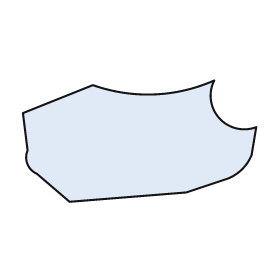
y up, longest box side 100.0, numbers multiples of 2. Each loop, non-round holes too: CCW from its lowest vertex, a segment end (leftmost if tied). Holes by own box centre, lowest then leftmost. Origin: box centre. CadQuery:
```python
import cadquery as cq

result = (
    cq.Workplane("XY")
    .moveTo(-30.0, -26.0)
    .lineTo(20.0, -22.0)
    .lineTo(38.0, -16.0)
    .threePointArc((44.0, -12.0), (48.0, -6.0))
    .lineTo(50.0, 6.0)
    .threePointArc((34.0, 10.0), (32.0, 26.0))
    .threePointArc((6.0, 20.0), (-20.0, 24.0))
    .lineTo(-50.0, 12.0)
    .lineTo(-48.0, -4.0)
    .threePointArc((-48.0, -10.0), (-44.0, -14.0))
    .close()
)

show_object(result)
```